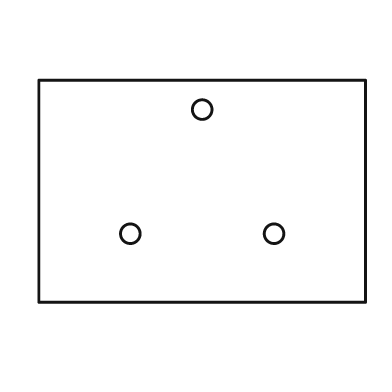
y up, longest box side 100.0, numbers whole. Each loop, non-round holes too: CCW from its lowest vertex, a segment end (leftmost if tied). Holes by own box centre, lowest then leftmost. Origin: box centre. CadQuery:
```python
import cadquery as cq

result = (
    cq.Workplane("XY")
    .moveTo(-50.0, -34.0)
    .lineTo(50.0, -34.0)
    .lineTo(50.0, 34.0)
    .lineTo(-50.0, 34.0)
    .close()
    .moveTo(-22.0, -13.0)
    .circle(3.0)
    .moveTo(22.0, -13.0)
    .circle(3.0)
    .moveTo(0.0, 25.0)
    .circle(3.0)
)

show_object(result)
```